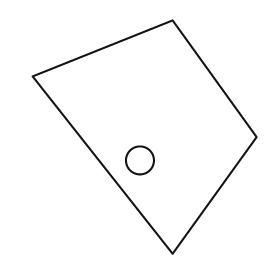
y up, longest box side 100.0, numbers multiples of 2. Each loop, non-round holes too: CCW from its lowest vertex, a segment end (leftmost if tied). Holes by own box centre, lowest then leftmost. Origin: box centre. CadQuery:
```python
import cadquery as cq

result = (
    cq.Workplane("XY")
    .moveTo(12.0, -50.0)
    .lineTo(48.0, 0.0)
    .lineTo(12.0, 50.0)
    .lineTo(-48.0, 26.0)
    .close()
    .moveTo(-2.0, -10.0)
    .circle(6.0)
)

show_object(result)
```